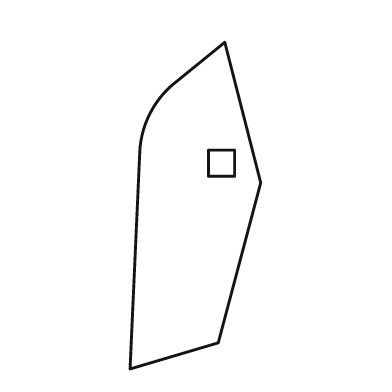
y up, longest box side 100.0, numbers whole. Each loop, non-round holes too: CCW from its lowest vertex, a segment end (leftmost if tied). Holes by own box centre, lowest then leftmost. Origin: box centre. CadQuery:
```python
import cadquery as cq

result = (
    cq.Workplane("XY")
    .moveTo(-20.0, -50.0)
    .lineTo(7.0, -42.0)
    .lineTo(20.0, 7.0)
    .lineTo(9.0, 50.0)
    .lineTo(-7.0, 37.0)
    .threePointArc((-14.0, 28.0), (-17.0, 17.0))
    .close()
    .moveTo(4.0, 9.0)
    .lineTo(12.0, 9.0)
    .lineTo(12.0, 17.0)
    .lineTo(4.0, 17.0)
    .close()
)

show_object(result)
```